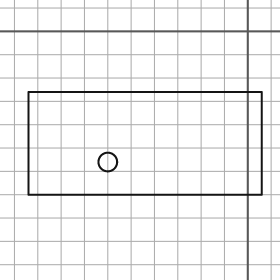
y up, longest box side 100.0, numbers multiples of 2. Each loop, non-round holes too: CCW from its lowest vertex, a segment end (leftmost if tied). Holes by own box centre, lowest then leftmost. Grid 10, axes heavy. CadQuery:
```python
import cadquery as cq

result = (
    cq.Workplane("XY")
    .moveTo(-94.0, -70.0)
    .lineTo(6.0, -70.0)
    .lineTo(6.0, -26.0)
    .lineTo(-94.0, -26.0)
    .close()
    .moveTo(-60.0, -56.0)
    .circle(4.0)
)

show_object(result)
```